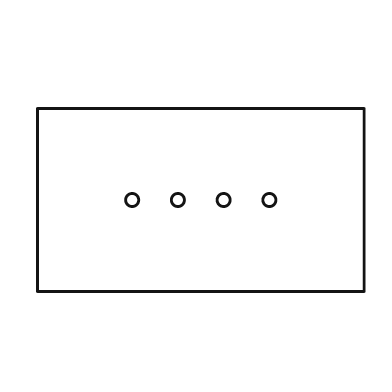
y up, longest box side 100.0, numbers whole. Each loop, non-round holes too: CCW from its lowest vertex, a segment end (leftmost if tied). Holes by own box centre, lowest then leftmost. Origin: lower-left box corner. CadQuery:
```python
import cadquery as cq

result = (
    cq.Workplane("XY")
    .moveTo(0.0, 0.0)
    .lineTo(100.0, 0.0)
    .lineTo(100.0, 56.0)
    .lineTo(0.0, 56.0)
    .close()
    .moveTo(29.0, 28.0)
    .circle(2.0)
    .moveTo(43.0, 28.0)
    .circle(2.0)
    .moveTo(57.0, 28.0)
    .circle(2.0)
    .moveTo(71.0, 28.0)
    .circle(2.0)
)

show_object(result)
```